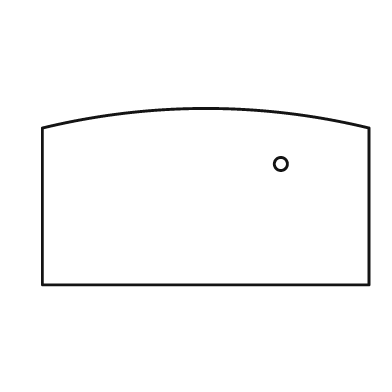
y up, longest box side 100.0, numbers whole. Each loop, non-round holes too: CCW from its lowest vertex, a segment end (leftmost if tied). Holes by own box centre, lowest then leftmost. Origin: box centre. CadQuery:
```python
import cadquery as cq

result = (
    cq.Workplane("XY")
    .moveTo(-50.0, -27.0)
    .lineTo(50.0, -27.0)
    .lineTo(50.0, 21.0)
    .threePointArc((0.0, 27.0), (-50.0, 21.0))
    .close()
    .moveTo(23.0, 10.0)
    .circle(2.0)
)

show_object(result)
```